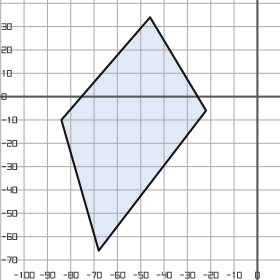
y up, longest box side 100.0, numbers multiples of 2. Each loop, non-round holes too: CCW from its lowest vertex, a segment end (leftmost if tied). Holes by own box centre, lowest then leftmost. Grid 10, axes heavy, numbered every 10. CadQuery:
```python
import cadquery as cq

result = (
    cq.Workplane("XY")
    .moveTo(-68.0, -66.0)
    .lineTo(-22.0, -6.0)
    .lineTo(-46.0, 34.0)
    .lineTo(-84.0, -10.0)
    .close()
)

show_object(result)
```